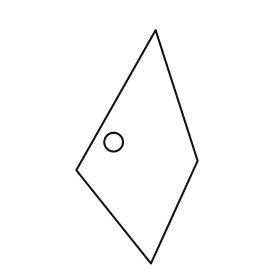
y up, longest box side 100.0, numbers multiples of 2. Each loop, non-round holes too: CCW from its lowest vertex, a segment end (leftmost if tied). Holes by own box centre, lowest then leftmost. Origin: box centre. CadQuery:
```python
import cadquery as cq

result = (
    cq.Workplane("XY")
    .moveTo(6.0, -50.0)
    .lineTo(26.0, -6.0)
    .lineTo(8.0, 50.0)
    .lineTo(-26.0, -10.0)
    .close()
    .moveTo(-10.0, 2.0)
    .circle(4.0)
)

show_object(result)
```